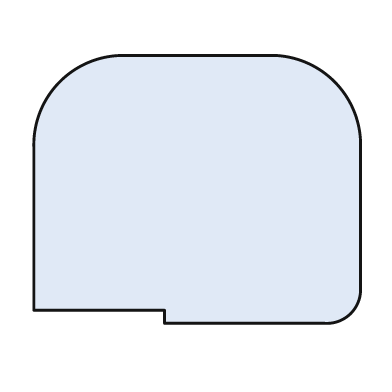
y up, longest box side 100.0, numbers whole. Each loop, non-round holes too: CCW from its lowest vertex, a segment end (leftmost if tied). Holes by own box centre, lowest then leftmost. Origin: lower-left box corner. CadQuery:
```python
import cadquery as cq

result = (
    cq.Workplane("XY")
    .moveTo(40.0, 0.0)
    .lineTo(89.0, 0.0)
    .threePointArc((97.0, 3.0), (100.0, 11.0))
    .lineTo(100.0, 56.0)
    .threePointArc((92.0, 74.0), (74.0, 82.0))
    .lineTo(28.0, 82.0)
    .threePointArc((8.0, 74.0), (0.0, 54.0))
    .lineTo(0.0, 4.0)
    .lineTo(40.0, 4.0)
    .close()
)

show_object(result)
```